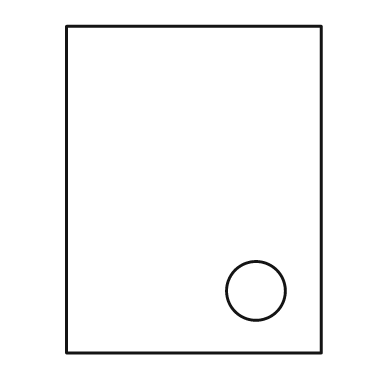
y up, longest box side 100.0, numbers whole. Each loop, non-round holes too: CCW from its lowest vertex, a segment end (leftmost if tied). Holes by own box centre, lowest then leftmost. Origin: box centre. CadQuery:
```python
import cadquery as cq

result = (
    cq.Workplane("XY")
    .moveTo(-39.0, -50.0)
    .lineTo(39.0, -50.0)
    .lineTo(39.0, 50.0)
    .lineTo(-39.0, 50.0)
    .close()
    .moveTo(19.0, -31.0)
    .circle(9.0)
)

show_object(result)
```